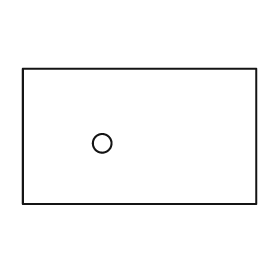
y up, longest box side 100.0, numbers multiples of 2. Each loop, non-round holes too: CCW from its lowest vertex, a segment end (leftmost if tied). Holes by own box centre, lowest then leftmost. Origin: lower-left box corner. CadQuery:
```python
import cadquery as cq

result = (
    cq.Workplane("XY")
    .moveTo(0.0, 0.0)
    .lineTo(100.0, 0.0)
    .lineTo(100.0, 58.0)
    .lineTo(0.0, 58.0)
    .close()
    .moveTo(34.0, 26.0)
    .circle(4.0)
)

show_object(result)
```